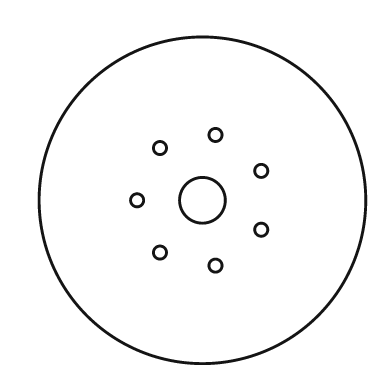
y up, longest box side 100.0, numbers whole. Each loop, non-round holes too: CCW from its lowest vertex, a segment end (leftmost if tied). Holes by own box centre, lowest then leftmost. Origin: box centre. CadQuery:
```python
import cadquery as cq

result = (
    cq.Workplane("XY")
    .moveTo(0.0, 0.0)
    .circle(50.0)
    .moveTo(4.0, -20.0)
    .circle(2.0)
    .moveTo(-13.0, -16.0)
    .circle(2.0)
    .moveTo(18.0, -9.0)
    .circle(2.0)
    .moveTo(-20.0, 0.0)
    .circle(2.0)
    .moveTo(0.0, 0.0)
    .circle(7.0)
    .moveTo(18.0, 9.0)
    .circle(2.0)
    .moveTo(-13.0, 16.0)
    .circle(2.0)
    .moveTo(4.0, 20.0)
    .circle(2.0)
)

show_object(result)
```